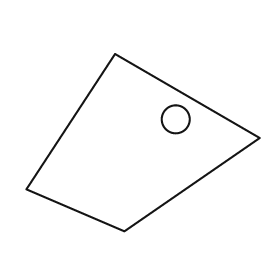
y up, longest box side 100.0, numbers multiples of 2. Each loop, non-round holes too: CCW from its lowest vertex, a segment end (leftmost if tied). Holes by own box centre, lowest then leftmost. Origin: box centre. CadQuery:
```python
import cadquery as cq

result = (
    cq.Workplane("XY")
    .moveTo(-8.0, -38.0)
    .lineTo(50.0, 2.0)
    .lineTo(-12.0, 38.0)
    .lineTo(-50.0, -20.0)
    .close()
    .moveTo(14.0, 10.0)
    .circle(6.0)
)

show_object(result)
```